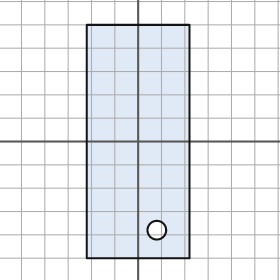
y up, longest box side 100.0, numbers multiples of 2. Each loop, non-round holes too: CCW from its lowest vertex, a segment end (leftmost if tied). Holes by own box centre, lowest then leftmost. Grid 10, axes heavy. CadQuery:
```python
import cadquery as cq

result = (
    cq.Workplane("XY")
    .moveTo(-22.0, -50.0)
    .lineTo(22.0, -50.0)
    .lineTo(22.0, 50.0)
    .lineTo(-22.0, 50.0)
    .close()
    .moveTo(8.0, -38.0)
    .circle(4.0)
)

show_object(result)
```